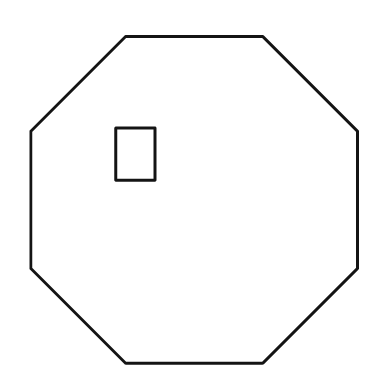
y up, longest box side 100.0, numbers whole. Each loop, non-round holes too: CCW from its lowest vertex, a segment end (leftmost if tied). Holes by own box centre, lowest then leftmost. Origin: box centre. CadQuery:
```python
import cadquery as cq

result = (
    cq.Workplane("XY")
    .moveTo(-21.0, -50.0)
    .lineTo(21.0, -50.0)
    .lineTo(50.0, -21.0)
    .lineTo(50.0, 21.0)
    .lineTo(21.0, 50.0)
    .lineTo(-21.0, 50.0)
    .lineTo(-50.0, 21.0)
    .lineTo(-50.0, -21.0)
    .close()
    .moveTo(-24.0, 6.0)
    .lineTo(-12.0, 6.0)
    .lineTo(-12.0, 22.0)
    .lineTo(-24.0, 22.0)
    .close()
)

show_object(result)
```